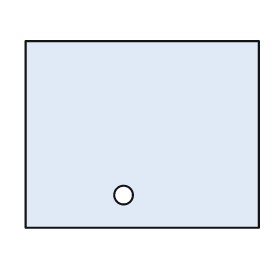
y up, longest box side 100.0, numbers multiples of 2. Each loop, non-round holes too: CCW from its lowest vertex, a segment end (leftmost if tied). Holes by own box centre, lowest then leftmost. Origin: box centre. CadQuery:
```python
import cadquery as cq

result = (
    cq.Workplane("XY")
    .moveTo(-50.0, -40.0)
    .lineTo(50.0, -40.0)
    .lineTo(50.0, 40.0)
    .lineTo(-50.0, 40.0)
    .close()
    .moveTo(-8.0, -26.0)
    .circle(4.0)
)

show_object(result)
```